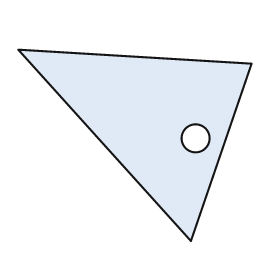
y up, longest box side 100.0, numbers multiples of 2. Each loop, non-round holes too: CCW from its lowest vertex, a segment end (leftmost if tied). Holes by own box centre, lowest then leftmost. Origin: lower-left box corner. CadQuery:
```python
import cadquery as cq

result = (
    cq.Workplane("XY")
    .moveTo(74.0, 0.0)
    .lineTo(100.0, 76.0)
    .lineTo(0.0, 82.0)
    .close()
    .moveTo(76.0, 44.0)
    .circle(6.0)
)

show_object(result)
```